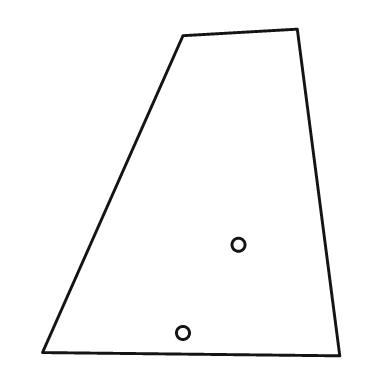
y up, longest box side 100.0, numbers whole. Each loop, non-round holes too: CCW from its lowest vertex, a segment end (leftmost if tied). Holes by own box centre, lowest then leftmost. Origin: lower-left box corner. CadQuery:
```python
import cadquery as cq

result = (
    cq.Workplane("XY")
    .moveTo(91.0, 0.0)
    .lineTo(78.0, 100.0)
    .lineTo(43.0, 98.0)
    .lineTo(0.0, 1.0)
    .close()
    .moveTo(43.0, 7.0)
    .circle(2.0)
    .moveTo(60.0, 34.0)
    .circle(2.0)
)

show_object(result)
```